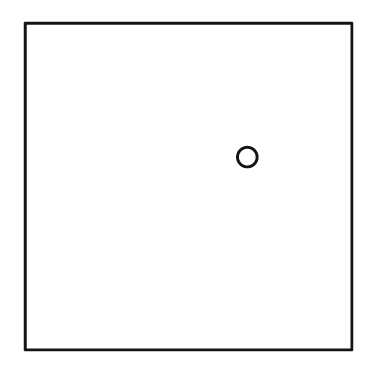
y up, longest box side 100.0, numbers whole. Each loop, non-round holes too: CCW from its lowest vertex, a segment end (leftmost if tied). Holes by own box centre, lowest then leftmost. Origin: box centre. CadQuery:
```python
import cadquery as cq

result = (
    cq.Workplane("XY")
    .moveTo(-50.0, -50.0)
    .lineTo(50.0, -50.0)
    .lineTo(50.0, 50.0)
    .lineTo(-50.0, 50.0)
    .close()
    .moveTo(18.0, 9.0)
    .circle(3.0)
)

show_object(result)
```